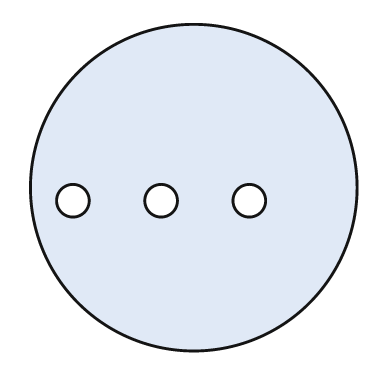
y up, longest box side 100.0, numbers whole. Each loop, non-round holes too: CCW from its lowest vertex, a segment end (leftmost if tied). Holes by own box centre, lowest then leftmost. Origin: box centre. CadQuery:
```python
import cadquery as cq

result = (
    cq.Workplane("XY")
    .moveTo(0.0, 0.0)
    .circle(50.0)
    .moveTo(-37.0, -4.0)
    .circle(5.0)
    .moveTo(-10.0, -4.0)
    .circle(5.0)
    .moveTo(17.0, -4.0)
    .circle(5.0)
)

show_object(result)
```